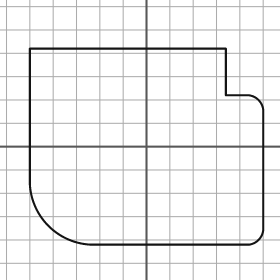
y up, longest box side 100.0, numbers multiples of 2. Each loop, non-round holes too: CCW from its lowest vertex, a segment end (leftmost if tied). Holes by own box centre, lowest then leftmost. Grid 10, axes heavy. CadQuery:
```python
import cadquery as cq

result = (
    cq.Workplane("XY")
    .moveTo(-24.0, -42.0)
    .lineTo(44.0, -42.0)
    .threePointArc((48.0, -40.0), (50.0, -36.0))
    .lineTo(50.0, 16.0)
    .threePointArc((48.0, 20.0), (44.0, 22.0))
    .lineTo(34.0, 22.0)
    .lineTo(34.0, 42.0)
    .lineTo(-50.0, 42.0)
    .lineTo(-50.0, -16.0)
    .threePointArc((-42.0, -34.0), (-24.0, -42.0))
    .close()
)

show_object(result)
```